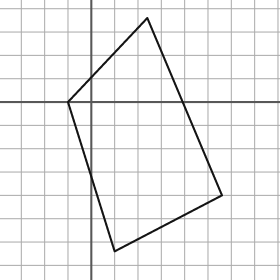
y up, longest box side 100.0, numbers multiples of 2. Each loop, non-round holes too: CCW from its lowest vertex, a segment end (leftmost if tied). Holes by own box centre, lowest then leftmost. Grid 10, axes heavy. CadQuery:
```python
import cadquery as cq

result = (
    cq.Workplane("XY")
    .moveTo(10.0, -64.0)
    .lineTo(56.0, -40.0)
    .lineTo(24.0, 36.0)
    .lineTo(-10.0, 0.0)
    .close()
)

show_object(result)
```